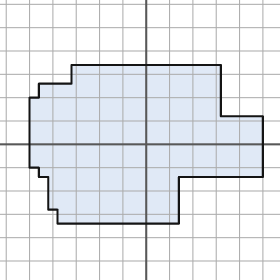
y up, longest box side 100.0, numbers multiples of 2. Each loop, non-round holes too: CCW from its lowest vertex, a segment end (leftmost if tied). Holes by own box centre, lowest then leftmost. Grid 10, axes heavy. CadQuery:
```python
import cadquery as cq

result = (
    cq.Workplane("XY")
    .moveTo(-38.0, -34.0)
    .lineTo(14.0, -34.0)
    .lineTo(14.0, -14.0)
    .lineTo(50.0, -14.0)
    .lineTo(50.0, 12.0)
    .lineTo(32.0, 12.0)
    .lineTo(32.0, 34.0)
    .lineTo(-32.0, 34.0)
    .lineTo(-32.0, 26.0)
    .lineTo(-46.0, 26.0)
    .lineTo(-46.0, 20.0)
    .lineTo(-50.0, 20.0)
    .lineTo(-50.0, -10.0)
    .lineTo(-46.0, -10.0)
    .lineTo(-46.0, -14.0)
    .lineTo(-42.0, -14.0)
    .lineTo(-42.0, -28.0)
    .lineTo(-38.0, -28.0)
    .close()
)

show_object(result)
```